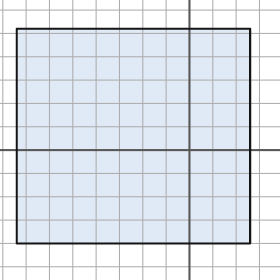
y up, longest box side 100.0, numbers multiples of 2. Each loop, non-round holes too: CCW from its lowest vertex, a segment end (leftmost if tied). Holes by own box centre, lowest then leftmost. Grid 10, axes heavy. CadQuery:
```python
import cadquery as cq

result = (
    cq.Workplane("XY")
    .moveTo(-74.0, -40.0)
    .lineTo(26.0, -40.0)
    .lineTo(26.0, 52.0)
    .lineTo(-74.0, 52.0)
    .close()
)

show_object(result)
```